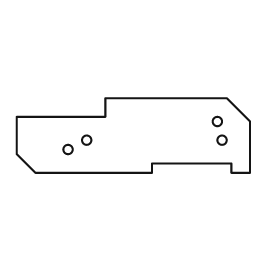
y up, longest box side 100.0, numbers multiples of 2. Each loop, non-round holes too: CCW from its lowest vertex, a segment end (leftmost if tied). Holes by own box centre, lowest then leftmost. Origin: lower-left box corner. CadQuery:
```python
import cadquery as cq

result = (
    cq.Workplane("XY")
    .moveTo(8.0, 0.0)
    .lineTo(58.0, 0.0)
    .lineTo(58.0, 4.0)
    .lineTo(92.0, 4.0)
    .lineTo(92.0, 0.0)
    .lineTo(100.0, 0.0)
    .lineTo(100.0, 22.0)
    .lineTo(90.0, 32.0)
    .lineTo(38.0, 32.0)
    .lineTo(38.0, 24.0)
    .lineTo(0.0, 24.0)
    .lineTo(0.0, 8.0)
    .close()
    .moveTo(22.0, 10.0)
    .circle(2.0)
    .moveTo(30.0, 14.0)
    .circle(2.0)
    .moveTo(88.0, 14.0)
    .circle(2.0)
    .moveTo(86.0, 22.0)
    .circle(2.0)
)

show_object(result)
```